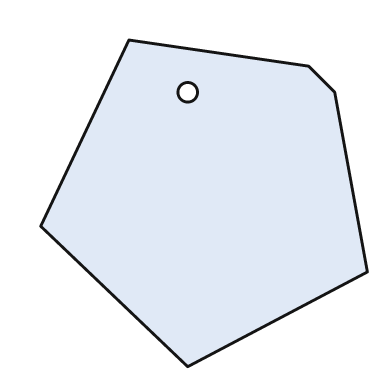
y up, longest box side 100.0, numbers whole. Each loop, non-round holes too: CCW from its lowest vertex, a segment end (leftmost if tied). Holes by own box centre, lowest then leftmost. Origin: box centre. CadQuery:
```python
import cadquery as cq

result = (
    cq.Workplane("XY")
    .moveTo(-5.0, -50.0)
    .lineTo(50.0, -21.0)
    .lineTo(40.0, 34.0)
    .lineTo(32.0, 42.0)
    .lineTo(-23.0, 50.0)
    .lineTo(-50.0, -7.0)
    .close()
    .moveTo(-5.0, 34.0)
    .circle(3.0)
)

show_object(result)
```